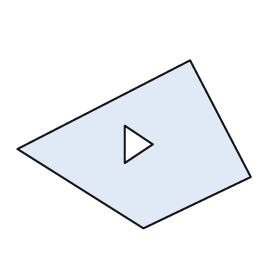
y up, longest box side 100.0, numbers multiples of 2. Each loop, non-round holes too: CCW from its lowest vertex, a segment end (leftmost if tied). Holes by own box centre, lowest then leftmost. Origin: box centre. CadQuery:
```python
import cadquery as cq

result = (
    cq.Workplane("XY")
    .moveTo(4.0, -36.0)
    .lineTo(50.0, -14.0)
    .lineTo(24.0, 36.0)
    .lineTo(-50.0, -2.0)
    .close()
    .moveTo(-4.0, -8.0)
    .lineTo(8.0, 0.0)
    .lineTo(-4.0, 8.0)
    .close()
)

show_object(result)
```